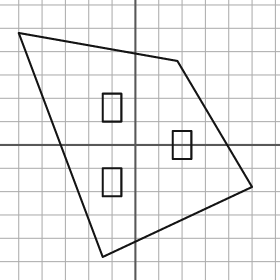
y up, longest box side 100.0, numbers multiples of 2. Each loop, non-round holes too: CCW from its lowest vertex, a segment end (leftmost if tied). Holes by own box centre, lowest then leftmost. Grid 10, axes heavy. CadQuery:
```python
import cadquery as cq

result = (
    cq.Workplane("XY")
    .moveTo(-14.0, -48.0)
    .lineTo(50.0, -18.0)
    .lineTo(18.0, 36.0)
    .lineTo(-50.0, 48.0)
    .close()
    .moveTo(-14.0, -22.0)
    .lineTo(-6.0, -22.0)
    .lineTo(-6.0, -10.0)
    .lineTo(-14.0, -10.0)
    .close()
    .moveTo(16.0, -6.0)
    .lineTo(24.0, -6.0)
    .lineTo(24.0, 6.0)
    .lineTo(16.0, 6.0)
    .close()
    .moveTo(-14.0, 10.0)
    .lineTo(-6.0, 10.0)
    .lineTo(-6.0, 22.0)
    .lineTo(-14.0, 22.0)
    .close()
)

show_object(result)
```